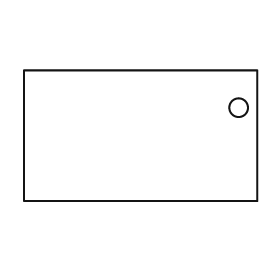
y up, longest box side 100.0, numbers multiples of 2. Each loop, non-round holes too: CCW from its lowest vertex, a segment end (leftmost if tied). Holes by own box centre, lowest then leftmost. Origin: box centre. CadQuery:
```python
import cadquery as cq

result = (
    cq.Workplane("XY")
    .moveTo(-50.0, -28.0)
    .lineTo(50.0, -28.0)
    .lineTo(50.0, 28.0)
    .lineTo(-50.0, 28.0)
    .close()
    .moveTo(42.0, 12.0)
    .circle(4.0)
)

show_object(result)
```